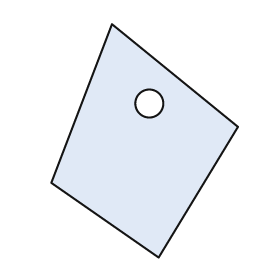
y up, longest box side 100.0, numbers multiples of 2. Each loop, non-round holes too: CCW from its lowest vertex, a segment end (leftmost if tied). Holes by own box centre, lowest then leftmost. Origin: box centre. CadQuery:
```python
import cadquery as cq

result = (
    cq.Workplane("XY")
    .moveTo(6.0, -50.0)
    .lineTo(40.0, 6.0)
    .lineTo(-14.0, 50.0)
    .lineTo(-40.0, -18.0)
    .close()
    .moveTo(2.0, 16.0)
    .circle(6.0)
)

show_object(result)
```